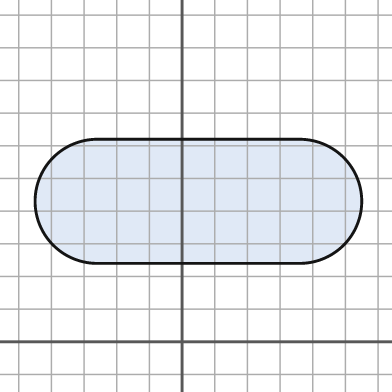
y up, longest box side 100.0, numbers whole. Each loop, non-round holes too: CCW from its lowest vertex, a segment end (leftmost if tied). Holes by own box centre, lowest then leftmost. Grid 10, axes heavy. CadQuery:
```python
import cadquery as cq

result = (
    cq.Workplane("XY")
    .moveTo(-26.0, 24.0)
    .lineTo(36.0, 24.0)
    .threePointArc((55.0, 43.0), (36.0, 62.0))
    .lineTo(-26.0, 62.0)
    .threePointArc((-45.0, 43.0), (-26.0, 24.0))
    .close()
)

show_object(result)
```